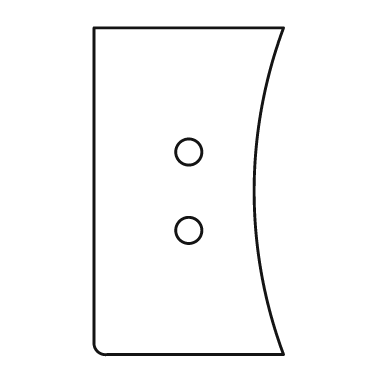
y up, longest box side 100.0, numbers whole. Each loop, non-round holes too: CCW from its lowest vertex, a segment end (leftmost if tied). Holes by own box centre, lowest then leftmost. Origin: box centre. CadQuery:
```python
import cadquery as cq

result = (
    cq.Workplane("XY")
    .moveTo(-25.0, -50.0)
    .lineTo(29.0, -50.0)
    .threePointArc((20.0, 0.0), (29.0, 50.0))
    .lineTo(-29.0, 50.0)
    .lineTo(-29.0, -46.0)
    .threePointArc((-28.0, -49.0), (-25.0, -50.0))
    .close()
    .moveTo(0.0, -12.0)
    .circle(4.0)
    .moveTo(0.0, 12.0)
    .circle(4.0)
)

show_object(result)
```